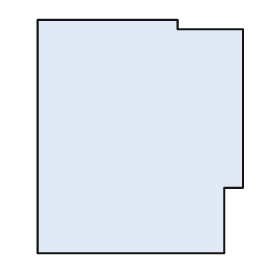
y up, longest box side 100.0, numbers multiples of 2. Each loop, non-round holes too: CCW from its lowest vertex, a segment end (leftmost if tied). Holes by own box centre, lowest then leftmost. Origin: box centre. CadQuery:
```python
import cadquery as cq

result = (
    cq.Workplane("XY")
    .moveTo(-44.0, -50.0)
    .lineTo(36.0, -50.0)
    .lineTo(36.0, -22.0)
    .lineTo(44.0, -22.0)
    .lineTo(44.0, 46.0)
    .lineTo(16.0, 46.0)
    .lineTo(16.0, 50.0)
    .lineTo(-44.0, 50.0)
    .close()
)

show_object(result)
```